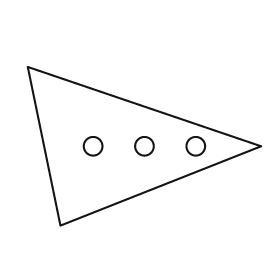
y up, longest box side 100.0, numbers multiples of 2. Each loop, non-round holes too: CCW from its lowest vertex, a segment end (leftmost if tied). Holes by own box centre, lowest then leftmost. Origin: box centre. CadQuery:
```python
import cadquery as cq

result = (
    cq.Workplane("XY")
    .moveTo(-36.0, -34.0)
    .lineTo(50.0, 0.0)
    .lineTo(-50.0, 34.0)
    .close()
    .moveTo(-22.0, 0.0)
    .circle(4.0)
    .moveTo(0.0, 0.0)
    .circle(4.0)
    .moveTo(22.0, 0.0)
    .circle(4.0)
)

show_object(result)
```